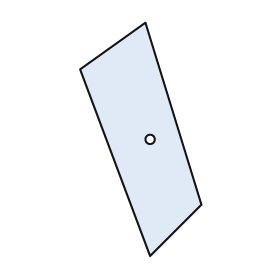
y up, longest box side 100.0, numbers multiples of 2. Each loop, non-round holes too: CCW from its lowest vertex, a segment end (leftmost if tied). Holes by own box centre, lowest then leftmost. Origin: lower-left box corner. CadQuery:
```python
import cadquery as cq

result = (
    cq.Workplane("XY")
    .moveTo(30.0, 0.0)
    .lineTo(52.0, 22.0)
    .lineTo(28.0, 100.0)
    .lineTo(0.0, 80.0)
    .close()
    .moveTo(30.0, 50.0)
    .circle(2.0)
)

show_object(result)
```